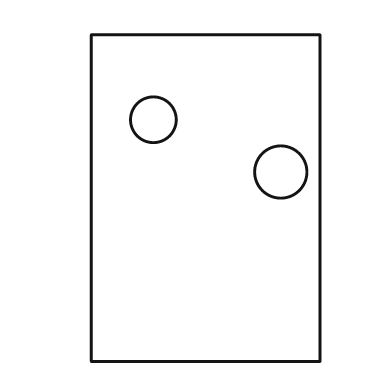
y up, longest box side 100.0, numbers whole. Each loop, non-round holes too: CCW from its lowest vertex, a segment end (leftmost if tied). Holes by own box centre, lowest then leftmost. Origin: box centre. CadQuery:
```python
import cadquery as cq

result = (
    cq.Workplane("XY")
    .moveTo(-35.0, -50.0)
    .lineTo(35.0, -50.0)
    .lineTo(35.0, 50.0)
    .lineTo(-35.0, 50.0)
    .close()
    .moveTo(23.0, 8.0)
    .circle(8.0)
    .moveTo(-16.0, 24.0)
    .circle(7.0)
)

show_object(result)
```